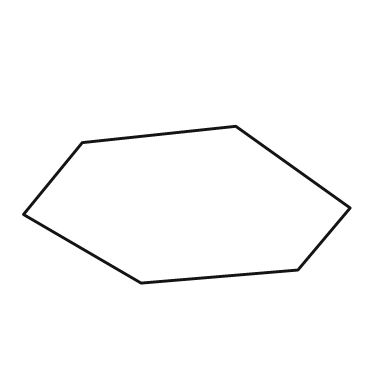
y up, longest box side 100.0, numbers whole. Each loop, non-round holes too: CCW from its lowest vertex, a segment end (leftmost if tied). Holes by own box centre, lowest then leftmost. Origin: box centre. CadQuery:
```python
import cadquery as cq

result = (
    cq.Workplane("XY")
    .moveTo(-14.0, -24.0)
    .lineTo(34.0, -20.0)
    .lineTo(50.0, -1.0)
    .lineTo(15.0, 24.0)
    .lineTo(-32.0, 19.0)
    .lineTo(-50.0, -3.0)
    .close()
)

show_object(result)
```